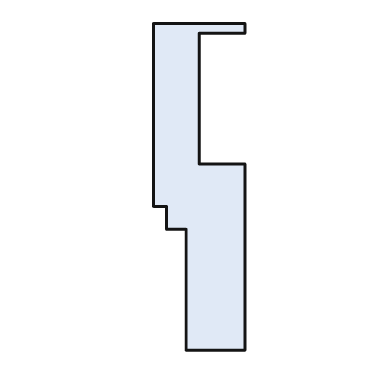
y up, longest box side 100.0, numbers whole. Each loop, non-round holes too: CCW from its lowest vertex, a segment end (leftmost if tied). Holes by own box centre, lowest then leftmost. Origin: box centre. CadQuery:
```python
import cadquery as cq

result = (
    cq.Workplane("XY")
    .moveTo(-4.0, -50.0)
    .lineTo(14.0, -50.0)
    .lineTo(14.0, 7.0)
    .lineTo(0.0, 7.0)
    .lineTo(0.0, 47.0)
    .lineTo(14.0, 47.0)
    .lineTo(14.0, 50.0)
    .lineTo(-14.0, 50.0)
    .lineTo(-14.0, -6.0)
    .lineTo(-10.0, -6.0)
    .lineTo(-10.0, -13.0)
    .lineTo(-4.0, -13.0)
    .close()
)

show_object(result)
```